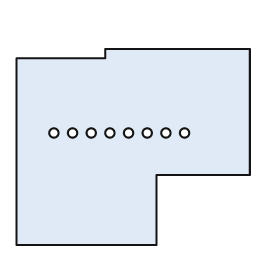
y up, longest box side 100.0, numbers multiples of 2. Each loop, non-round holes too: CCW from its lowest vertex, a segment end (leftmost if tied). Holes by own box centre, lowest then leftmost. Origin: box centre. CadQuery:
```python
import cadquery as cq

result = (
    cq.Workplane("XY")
    .moveTo(-50.0, -42.0)
    .lineTo(10.0, -42.0)
    .lineTo(10.0, -12.0)
    .lineTo(50.0, -12.0)
    .lineTo(50.0, 42.0)
    .lineTo(-12.0, 42.0)
    .lineTo(-12.0, 38.0)
    .lineTo(-50.0, 38.0)
    .close()
    .moveTo(-34.0, 6.0)
    .circle(2.0)
    .moveTo(-26.0, 6.0)
    .circle(2.0)
    .moveTo(-18.0, 6.0)
    .circle(2.0)
    .moveTo(-10.0, 6.0)
    .circle(2.0)
    .moveTo(-2.0, 6.0)
    .circle(2.0)
    .moveTo(6.0, 6.0)
    .circle(2.0)
    .moveTo(14.0, 6.0)
    .circle(2.0)
    .moveTo(22.0, 6.0)
    .circle(2.0)
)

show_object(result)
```